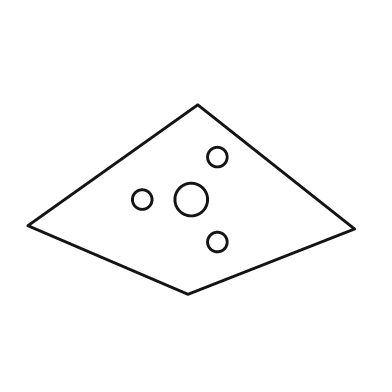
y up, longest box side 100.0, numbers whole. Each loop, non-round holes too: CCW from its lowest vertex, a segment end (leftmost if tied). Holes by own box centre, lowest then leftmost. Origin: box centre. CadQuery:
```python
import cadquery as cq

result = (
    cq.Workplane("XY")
    .moveTo(-1.0, -29.0)
    .lineTo(50.0, -9.0)
    .lineTo(2.0, 29.0)
    .lineTo(-50.0, -8.0)
    .close()
    .moveTo(8.0, -13.0)
    .circle(3.0)
    .moveTo(-15.0, 0.0)
    .circle(3.0)
    .moveTo(0.0, 0.0)
    .circle(5.0)
    .moveTo(8.0, 13.0)
    .circle(3.0)
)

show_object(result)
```